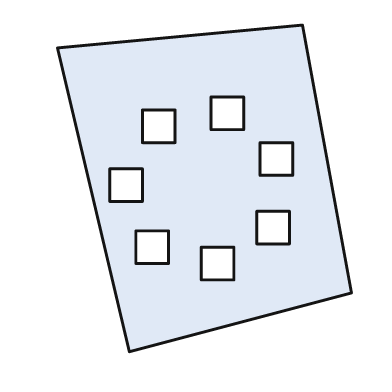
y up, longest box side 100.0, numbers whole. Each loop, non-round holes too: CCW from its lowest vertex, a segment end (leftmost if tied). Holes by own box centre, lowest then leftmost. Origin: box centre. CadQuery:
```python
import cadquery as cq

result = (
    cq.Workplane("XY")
    .moveTo(-23.0, -50.0)
    .lineTo(45.0, -32.0)
    .lineTo(30.0, 50.0)
    .lineTo(-45.0, 43.0)
    .close()
    .moveTo(-1.0, -28.0)
    .lineTo(9.0, -28.0)
    .lineTo(9.0, -18.0)
    .lineTo(-1.0, -18.0)
    .close()
    .moveTo(-21.0, -23.0)
    .lineTo(-11.0, -23.0)
    .lineTo(-11.0, -13.0)
    .lineTo(-21.0, -13.0)
    .close()
    .moveTo(16.0, -17.0)
    .lineTo(26.0, -17.0)
    .lineTo(26.0, -7.0)
    .lineTo(16.0, -7.0)
    .close()
    .moveTo(-29.0, -4.0)
    .lineTo(-19.0, -4.0)
    .lineTo(-19.0, 6.0)
    .lineTo(-29.0, 6.0)
    .close()
    .moveTo(17.0, 4.0)
    .lineTo(27.0, 4.0)
    .lineTo(27.0, 14.0)
    .lineTo(17.0, 14.0)
    .close()
    .moveTo(-19.0, 14.0)
    .lineTo(-9.0, 14.0)
    .lineTo(-9.0, 24.0)
    .lineTo(-19.0, 24.0)
    .close()
    .moveTo(2.0, 18.0)
    .lineTo(12.0, 18.0)
    .lineTo(12.0, 28.0)
    .lineTo(2.0, 28.0)
    .close()
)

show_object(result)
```